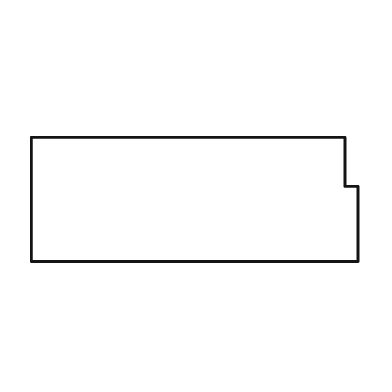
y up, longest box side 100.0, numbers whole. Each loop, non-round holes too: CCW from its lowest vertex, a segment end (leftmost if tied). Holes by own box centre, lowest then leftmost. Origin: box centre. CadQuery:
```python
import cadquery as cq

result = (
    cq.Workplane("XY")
    .moveTo(-50.0, -19.0)
    .lineTo(50.0, -19.0)
    .lineTo(50.0, 4.0)
    .lineTo(46.0, 4.0)
    .lineTo(46.0, 19.0)
    .lineTo(-50.0, 19.0)
    .close()
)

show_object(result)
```